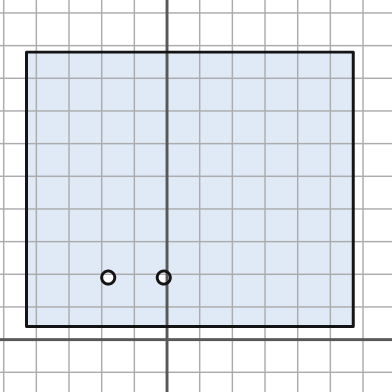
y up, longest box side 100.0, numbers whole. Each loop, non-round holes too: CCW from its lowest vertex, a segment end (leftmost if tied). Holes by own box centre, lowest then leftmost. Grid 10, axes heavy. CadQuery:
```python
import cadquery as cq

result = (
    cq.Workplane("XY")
    .moveTo(-43.0, 4.0)
    .lineTo(57.0, 4.0)
    .lineTo(57.0, 88.0)
    .lineTo(-43.0, 88.0)
    .close()
    .moveTo(-18.0, 19.0)
    .circle(2.0)
    .moveTo(-1.0, 19.0)
    .circle(2.0)
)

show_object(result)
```